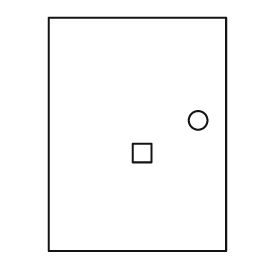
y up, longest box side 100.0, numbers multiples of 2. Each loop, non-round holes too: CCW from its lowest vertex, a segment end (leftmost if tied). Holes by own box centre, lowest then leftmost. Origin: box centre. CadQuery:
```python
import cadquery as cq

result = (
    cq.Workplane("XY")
    .moveTo(-38.0, -50.0)
    .lineTo(38.0, -50.0)
    .lineTo(38.0, 50.0)
    .lineTo(-38.0, 50.0)
    .close()
    .moveTo(-2.0, -12.0)
    .lineTo(6.0, -12.0)
    .lineTo(6.0, -4.0)
    .lineTo(-2.0, -4.0)
    .close()
    .moveTo(26.0, 6.0)
    .circle(4.0)
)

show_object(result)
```